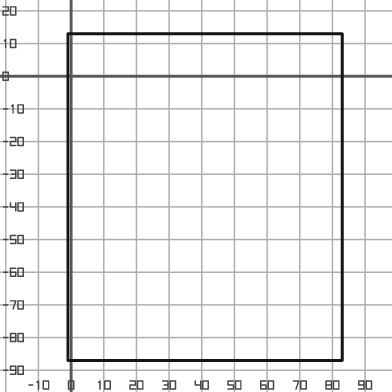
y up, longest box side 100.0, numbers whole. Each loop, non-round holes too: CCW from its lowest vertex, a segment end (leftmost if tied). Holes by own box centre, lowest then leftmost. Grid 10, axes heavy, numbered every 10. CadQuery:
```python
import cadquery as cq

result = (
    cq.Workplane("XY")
    .moveTo(-1.0, -87.0)
    .lineTo(83.0, -87.0)
    .lineTo(83.0, 13.0)
    .lineTo(-1.0, 13.0)
    .close()
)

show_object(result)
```